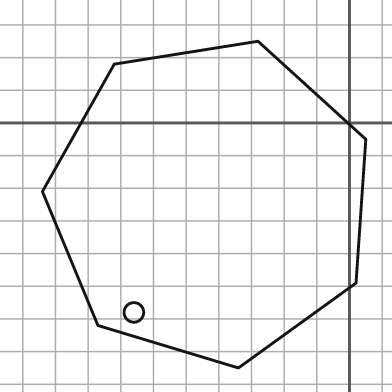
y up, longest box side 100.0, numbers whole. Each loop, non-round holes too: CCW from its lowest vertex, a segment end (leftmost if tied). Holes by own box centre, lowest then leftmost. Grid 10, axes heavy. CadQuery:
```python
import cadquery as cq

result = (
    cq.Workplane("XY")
    .moveTo(-34.0, -75.0)
    .lineTo(2.0, -49.0)
    .lineTo(5.0, -5.0)
    .lineTo(-28.0, 25.0)
    .lineTo(-72.0, 18.0)
    .lineTo(-94.0, -21.0)
    .lineTo(-77.0, -62.0)
    .close()
    .moveTo(-66.0, -58.0)
    .circle(3.0)
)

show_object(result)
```